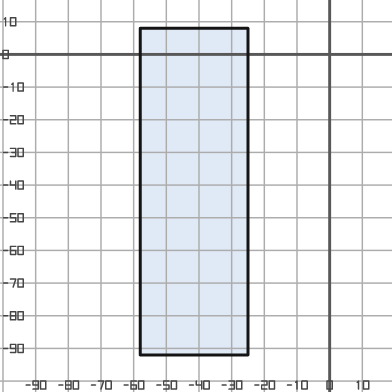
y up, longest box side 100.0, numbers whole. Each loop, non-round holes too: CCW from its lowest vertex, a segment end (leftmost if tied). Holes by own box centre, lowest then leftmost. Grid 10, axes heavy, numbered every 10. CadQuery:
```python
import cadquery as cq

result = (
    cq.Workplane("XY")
    .moveTo(-58.0, -92.0)
    .lineTo(-25.0, -92.0)
    .lineTo(-25.0, 8.0)
    .lineTo(-58.0, 8.0)
    .close()
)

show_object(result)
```